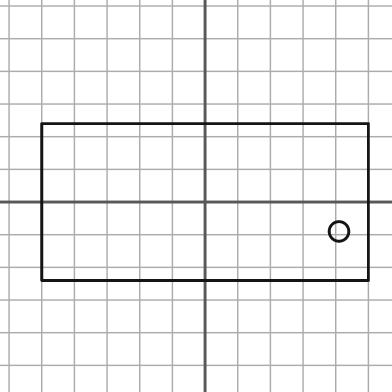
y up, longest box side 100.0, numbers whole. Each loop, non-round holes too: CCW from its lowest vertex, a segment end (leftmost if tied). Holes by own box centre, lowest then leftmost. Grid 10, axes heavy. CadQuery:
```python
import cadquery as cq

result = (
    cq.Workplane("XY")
    .moveTo(-50.0, -24.0)
    .lineTo(50.0, -24.0)
    .lineTo(50.0, 24.0)
    .lineTo(-50.0, 24.0)
    .close()
    .moveTo(41.0, -9.0)
    .circle(3.0)
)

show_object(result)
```